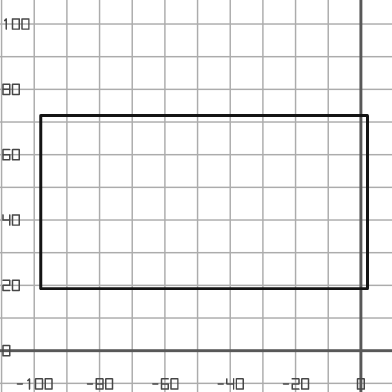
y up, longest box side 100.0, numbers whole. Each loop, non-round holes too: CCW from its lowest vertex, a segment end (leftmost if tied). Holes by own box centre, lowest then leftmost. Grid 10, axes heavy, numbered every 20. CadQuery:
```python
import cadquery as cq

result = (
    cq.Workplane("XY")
    .moveTo(-98.0, 19.0)
    .lineTo(2.0, 19.0)
    .lineTo(2.0, 72.0)
    .lineTo(-98.0, 72.0)
    .close()
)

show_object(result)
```